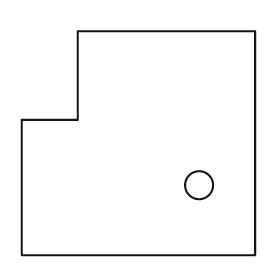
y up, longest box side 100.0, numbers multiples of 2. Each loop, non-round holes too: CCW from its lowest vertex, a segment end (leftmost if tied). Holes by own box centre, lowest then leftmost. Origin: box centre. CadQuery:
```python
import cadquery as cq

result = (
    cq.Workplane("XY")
    .moveTo(-50.0, -48.0)
    .lineTo(50.0, -48.0)
    .lineTo(50.0, 48.0)
    .lineTo(-26.0, 48.0)
    .lineTo(-26.0, 10.0)
    .lineTo(-50.0, 10.0)
    .close()
    .moveTo(26.0, -18.0)
    .circle(6.0)
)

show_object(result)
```